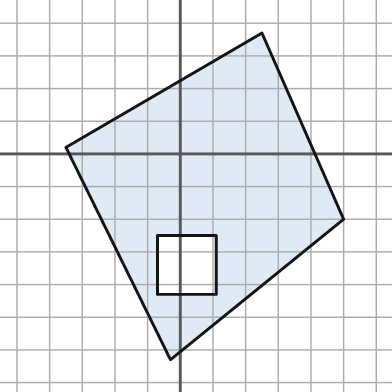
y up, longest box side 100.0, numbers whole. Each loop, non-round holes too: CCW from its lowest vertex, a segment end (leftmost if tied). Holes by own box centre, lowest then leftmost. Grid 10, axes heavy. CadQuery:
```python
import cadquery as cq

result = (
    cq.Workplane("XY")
    .moveTo(-3.0, -63.0)
    .lineTo(50.0, -20.0)
    .lineTo(25.0, 37.0)
    .lineTo(-35.0, 2.0)
    .close()
    .moveTo(-7.0, -43.0)
    .lineTo(11.0, -43.0)
    .lineTo(11.0, -25.0)
    .lineTo(-7.0, -25.0)
    .close()
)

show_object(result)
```